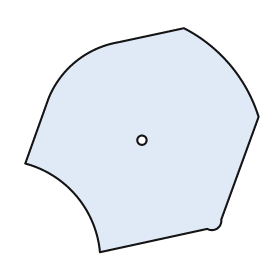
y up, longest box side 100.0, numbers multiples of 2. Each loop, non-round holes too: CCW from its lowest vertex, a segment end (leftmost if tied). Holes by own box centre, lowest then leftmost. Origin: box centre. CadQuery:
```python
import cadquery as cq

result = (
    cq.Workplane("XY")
    .moveTo(-18.0, -48.0)
    .lineTo(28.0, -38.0)
    .threePointArc((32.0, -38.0), (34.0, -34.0))
    .lineTo(50.0, 10.0)
    .threePointArc((38.0, 32.0), (18.0, 48.0))
    .lineTo(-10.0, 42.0)
    .threePointArc((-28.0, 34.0), (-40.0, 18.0))
    .lineTo(-50.0, -10.0)
    .threePointArc((-28.0, -24.0), (-18.0, -48.0))
    .close()
    .moveTo(0.0, 0.0)
    .circle(2.0)
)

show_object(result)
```